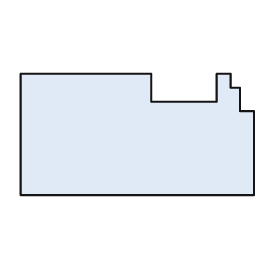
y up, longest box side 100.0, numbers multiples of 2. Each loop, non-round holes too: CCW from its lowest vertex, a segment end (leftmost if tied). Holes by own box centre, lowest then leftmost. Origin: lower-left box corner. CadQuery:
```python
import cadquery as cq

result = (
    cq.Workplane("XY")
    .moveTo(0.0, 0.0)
    .lineTo(100.0, 0.0)
    .lineTo(100.0, 36.0)
    .lineTo(94.0, 36.0)
    .lineTo(94.0, 46.0)
    .lineTo(90.0, 46.0)
    .lineTo(90.0, 52.0)
    .lineTo(84.0, 52.0)
    .lineTo(84.0, 40.0)
    .lineTo(56.0, 40.0)
    .lineTo(56.0, 52.0)
    .lineTo(0.0, 52.0)
    .close()
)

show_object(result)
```